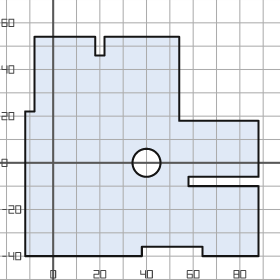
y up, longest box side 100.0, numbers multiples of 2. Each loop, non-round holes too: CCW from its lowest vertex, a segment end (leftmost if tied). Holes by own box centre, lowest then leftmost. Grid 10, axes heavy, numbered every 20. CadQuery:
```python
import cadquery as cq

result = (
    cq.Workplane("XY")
    .moveTo(-12.0, -40.0)
    .lineTo(38.0, -40.0)
    .lineTo(38.0, -36.0)
    .lineTo(64.0, -36.0)
    .lineTo(64.0, -40.0)
    .lineTo(88.0, -40.0)
    .lineTo(88.0, -10.0)
    .lineTo(58.0, -10.0)
    .lineTo(58.0, -6.0)
    .lineTo(88.0, -6.0)
    .lineTo(88.0, 18.0)
    .lineTo(54.0, 18.0)
    .lineTo(54.0, 54.0)
    .lineTo(22.0, 54.0)
    .lineTo(22.0, 46.0)
    .lineTo(18.0, 46.0)
    .lineTo(18.0, 54.0)
    .lineTo(-8.0, 54.0)
    .lineTo(-8.0, 22.0)
    .lineTo(-12.0, 22.0)
    .close()
    .moveTo(40.0, 0.0)
    .circle(6.0)
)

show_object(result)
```